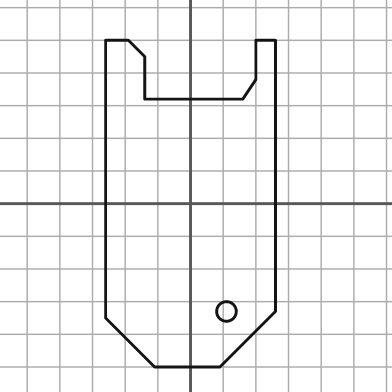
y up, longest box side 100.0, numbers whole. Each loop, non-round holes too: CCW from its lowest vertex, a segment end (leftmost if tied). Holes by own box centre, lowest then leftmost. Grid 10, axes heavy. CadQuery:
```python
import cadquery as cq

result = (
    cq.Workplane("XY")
    .moveTo(-11.0, -50.0)
    .lineTo(9.0, -50.0)
    .lineTo(26.0, -33.0)
    .lineTo(26.0, 50.0)
    .lineTo(20.0, 50.0)
    .lineTo(20.0, 38.0)
    .lineTo(16.0, 32.0)
    .lineTo(-14.0, 32.0)
    .lineTo(-14.0, 45.0)
    .lineTo(-19.0, 50.0)
    .lineTo(-26.0, 50.0)
    .lineTo(-26.0, -35.0)
    .close()
    .moveTo(11.0, -33.0)
    .circle(3.0)
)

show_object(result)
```